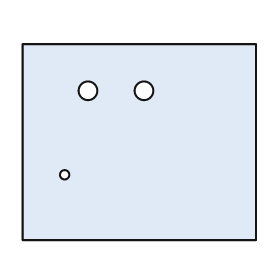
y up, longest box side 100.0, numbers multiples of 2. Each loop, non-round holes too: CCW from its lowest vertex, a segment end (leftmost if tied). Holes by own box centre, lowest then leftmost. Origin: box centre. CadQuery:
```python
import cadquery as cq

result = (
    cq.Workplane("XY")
    .moveTo(-50.0, -42.0)
    .lineTo(50.0, -42.0)
    .lineTo(50.0, 42.0)
    .lineTo(-50.0, 42.0)
    .close()
    .moveTo(-32.0, -14.0)
    .circle(2.0)
    .moveTo(-22.0, 22.0)
    .circle(4.0)
    .moveTo(2.0, 22.0)
    .circle(4.0)
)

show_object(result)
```